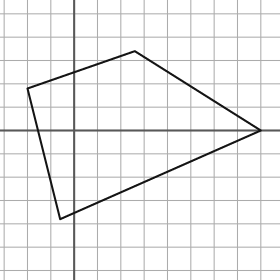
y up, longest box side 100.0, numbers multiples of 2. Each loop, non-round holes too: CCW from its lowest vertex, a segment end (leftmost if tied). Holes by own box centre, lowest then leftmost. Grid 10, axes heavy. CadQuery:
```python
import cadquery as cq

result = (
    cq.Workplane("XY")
    .moveTo(-6.0, -38.0)
    .lineTo(80.0, 0.0)
    .lineTo(26.0, 34.0)
    .lineTo(-20.0, 18.0)
    .close()
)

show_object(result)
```